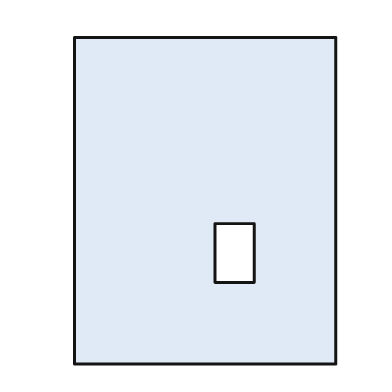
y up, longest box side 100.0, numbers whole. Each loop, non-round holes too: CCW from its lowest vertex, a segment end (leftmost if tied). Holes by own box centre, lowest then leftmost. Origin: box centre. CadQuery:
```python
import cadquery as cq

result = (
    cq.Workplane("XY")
    .moveTo(-40.0, -50.0)
    .lineTo(40.0, -50.0)
    .lineTo(40.0, 50.0)
    .lineTo(-40.0, 50.0)
    .close()
    .moveTo(3.0, -25.0)
    .lineTo(15.0, -25.0)
    .lineTo(15.0, -7.0)
    .lineTo(3.0, -7.0)
    .close()
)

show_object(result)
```